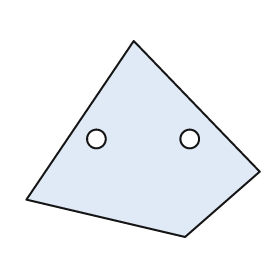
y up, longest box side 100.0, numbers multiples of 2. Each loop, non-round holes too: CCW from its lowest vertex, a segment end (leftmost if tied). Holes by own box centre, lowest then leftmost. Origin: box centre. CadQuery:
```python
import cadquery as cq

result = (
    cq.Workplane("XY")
    .moveTo(18.0, -42.0)
    .lineTo(50.0, -14.0)
    .lineTo(-4.0, 42.0)
    .lineTo(-50.0, -26.0)
    .close()
    .moveTo(-20.0, 0.0)
    .circle(4.0)
    .moveTo(20.0, 0.0)
    .circle(4.0)
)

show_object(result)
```